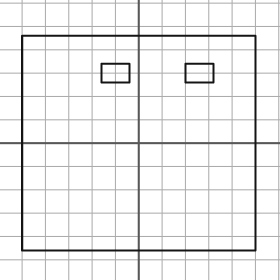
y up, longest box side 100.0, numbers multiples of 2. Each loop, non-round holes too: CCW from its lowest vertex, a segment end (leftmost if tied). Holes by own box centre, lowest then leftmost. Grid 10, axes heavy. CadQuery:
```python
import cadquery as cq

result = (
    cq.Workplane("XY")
    .moveTo(-50.0, -46.0)
    .lineTo(50.0, -46.0)
    .lineTo(50.0, 46.0)
    .lineTo(-50.0, 46.0)
    .close()
    .moveTo(-16.0, 26.0)
    .lineTo(-4.0, 26.0)
    .lineTo(-4.0, 34.0)
    .lineTo(-16.0, 34.0)
    .close()
    .moveTo(20.0, 26.0)
    .lineTo(32.0, 26.0)
    .lineTo(32.0, 34.0)
    .lineTo(20.0, 34.0)
    .close()
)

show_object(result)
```